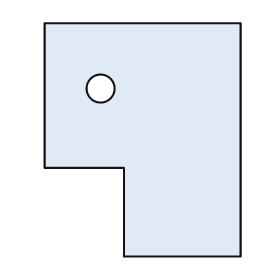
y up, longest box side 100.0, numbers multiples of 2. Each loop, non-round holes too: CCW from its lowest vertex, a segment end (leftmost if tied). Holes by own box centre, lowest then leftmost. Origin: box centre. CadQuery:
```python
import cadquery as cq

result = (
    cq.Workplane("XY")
    .moveTo(-8.0, -50.0)
    .lineTo(42.0, -50.0)
    .lineTo(42.0, 50.0)
    .lineTo(-42.0, 50.0)
    .lineTo(-42.0, -12.0)
    .lineTo(-8.0, -12.0)
    .close()
    .moveTo(-18.0, 22.0)
    .circle(6.0)
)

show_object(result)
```